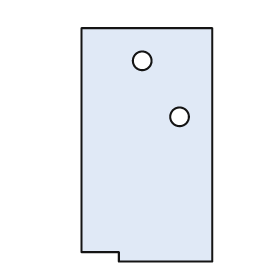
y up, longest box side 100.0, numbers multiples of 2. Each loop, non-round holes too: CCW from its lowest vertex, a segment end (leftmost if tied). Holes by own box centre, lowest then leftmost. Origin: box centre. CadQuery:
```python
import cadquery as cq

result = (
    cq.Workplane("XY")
    .moveTo(-12.0, -50.0)
    .lineTo(28.0, -50.0)
    .lineTo(28.0, 50.0)
    .lineTo(-28.0, 50.0)
    .lineTo(-28.0, -46.0)
    .lineTo(-12.0, -46.0)
    .close()
    .moveTo(14.0, 12.0)
    .circle(4.0)
    .moveTo(-2.0, 36.0)
    .circle(4.0)
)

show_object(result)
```